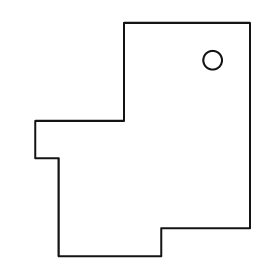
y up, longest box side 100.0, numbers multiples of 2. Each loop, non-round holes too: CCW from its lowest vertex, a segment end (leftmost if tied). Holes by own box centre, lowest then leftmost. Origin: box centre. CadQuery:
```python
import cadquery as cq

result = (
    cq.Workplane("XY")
    .moveTo(-36.0, -50.0)
    .lineTo(8.0, -50.0)
    .lineTo(8.0, -38.0)
    .lineTo(46.0, -38.0)
    .lineTo(46.0, 50.0)
    .lineTo(-8.0, 50.0)
    .lineTo(-8.0, 8.0)
    .lineTo(-46.0, 8.0)
    .lineTo(-46.0, -8.0)
    .lineTo(-36.0, -8.0)
    .close()
    .moveTo(30.0, 34.0)
    .circle(4.0)
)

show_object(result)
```